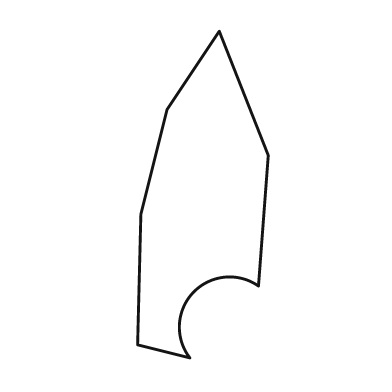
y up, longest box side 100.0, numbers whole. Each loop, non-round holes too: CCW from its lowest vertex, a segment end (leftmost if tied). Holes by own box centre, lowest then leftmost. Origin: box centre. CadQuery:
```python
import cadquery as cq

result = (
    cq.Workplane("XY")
    .moveTo(-4.0, -50.0)
    .threePointArc((-3.0, -30.0), (17.0, -28.0))
    .lineTo(20.0, 12.0)
    .lineTo(5.0, 50.0)
    .lineTo(-11.0, 26.0)
    .lineTo(-19.0, -6.0)
    .lineTo(-20.0, -46.0)
    .close()
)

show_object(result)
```